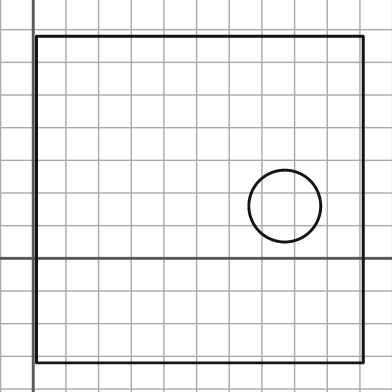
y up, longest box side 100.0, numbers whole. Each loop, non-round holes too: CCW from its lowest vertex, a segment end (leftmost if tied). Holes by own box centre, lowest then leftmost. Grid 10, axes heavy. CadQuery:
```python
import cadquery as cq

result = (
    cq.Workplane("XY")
    .moveTo(1.0, -32.0)
    .lineTo(101.0, -32.0)
    .lineTo(101.0, 68.0)
    .lineTo(1.0, 68.0)
    .close()
    .moveTo(77.0, 16.0)
    .circle(11.0)
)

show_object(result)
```